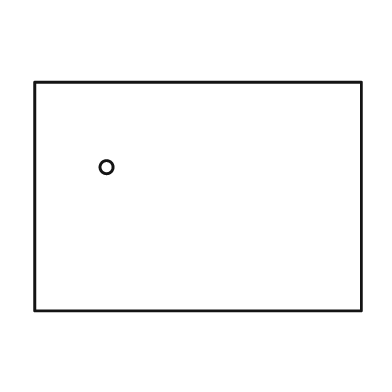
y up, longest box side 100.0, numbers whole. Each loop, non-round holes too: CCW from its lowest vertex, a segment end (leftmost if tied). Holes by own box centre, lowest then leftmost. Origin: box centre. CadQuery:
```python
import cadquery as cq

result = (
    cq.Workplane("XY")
    .moveTo(-50.0, -35.0)
    .lineTo(50.0, -35.0)
    .lineTo(50.0, 35.0)
    .lineTo(-50.0, 35.0)
    .close()
    .moveTo(-28.0, 9.0)
    .circle(2.0)
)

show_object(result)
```